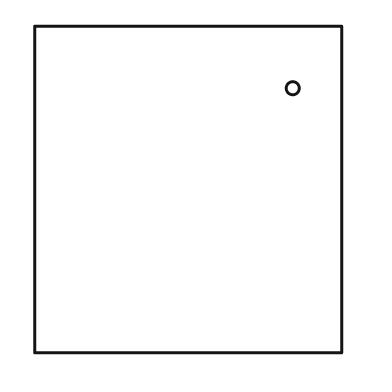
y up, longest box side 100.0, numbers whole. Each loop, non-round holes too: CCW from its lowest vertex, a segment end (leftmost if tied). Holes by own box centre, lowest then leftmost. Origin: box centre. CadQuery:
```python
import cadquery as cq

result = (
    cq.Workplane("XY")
    .moveTo(-47.0, -50.0)
    .lineTo(47.0, -50.0)
    .lineTo(47.0, 50.0)
    .lineTo(-47.0, 50.0)
    .close()
    .moveTo(32.0, 31.0)
    .circle(2.0)
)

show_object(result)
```